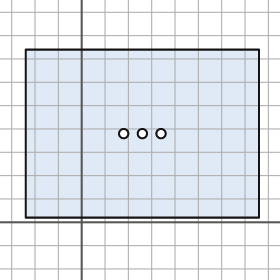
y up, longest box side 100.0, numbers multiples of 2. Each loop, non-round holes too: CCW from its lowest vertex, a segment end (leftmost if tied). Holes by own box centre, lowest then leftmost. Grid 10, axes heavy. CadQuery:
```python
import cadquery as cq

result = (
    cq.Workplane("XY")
    .moveTo(-24.0, 2.0)
    .lineTo(76.0, 2.0)
    .lineTo(76.0, 74.0)
    .lineTo(-24.0, 74.0)
    .close()
    .moveTo(18.0, 38.0)
    .circle(2.0)
    .moveTo(26.0, 38.0)
    .circle(2.0)
    .moveTo(34.0, 38.0)
    .circle(2.0)
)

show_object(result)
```